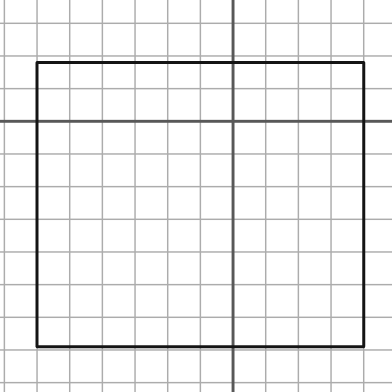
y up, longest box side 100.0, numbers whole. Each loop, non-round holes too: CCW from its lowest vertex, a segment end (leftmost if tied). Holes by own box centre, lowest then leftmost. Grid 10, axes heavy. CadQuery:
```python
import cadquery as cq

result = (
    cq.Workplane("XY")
    .moveTo(-60.0, -69.0)
    .lineTo(40.0, -69.0)
    .lineTo(40.0, 18.0)
    .lineTo(-60.0, 18.0)
    .close()
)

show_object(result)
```